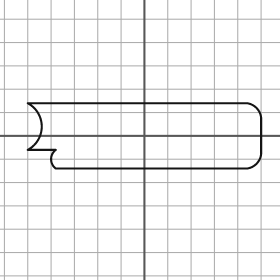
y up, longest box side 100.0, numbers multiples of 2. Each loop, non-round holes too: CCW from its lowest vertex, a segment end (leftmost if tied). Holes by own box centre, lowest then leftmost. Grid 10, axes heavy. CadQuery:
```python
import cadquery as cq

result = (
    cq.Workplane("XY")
    .moveTo(-38.0, -14.0)
    .lineTo(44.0, -14.0)
    .threePointArc((48.0, -12.0), (50.0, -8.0))
    .lineTo(50.0, 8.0)
    .threePointArc((48.0, 12.0), (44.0, 14.0))
    .lineTo(-50.0, 14.0)
    .threePointArc((-44.0, 4.0), (-50.0, -6.0))
    .lineTo(-38.0, -6.0)
    .threePointArc((-40.0, -10.0), (-38.0, -14.0))
    .close()
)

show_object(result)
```